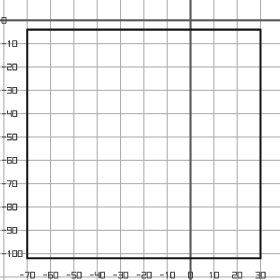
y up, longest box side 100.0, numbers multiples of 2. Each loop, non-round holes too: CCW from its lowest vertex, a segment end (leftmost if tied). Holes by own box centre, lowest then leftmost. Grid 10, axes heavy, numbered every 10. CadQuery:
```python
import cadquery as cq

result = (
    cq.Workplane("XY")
    .moveTo(-70.0, -102.0)
    .lineTo(30.0, -102.0)
    .lineTo(30.0, -4.0)
    .lineTo(-70.0, -4.0)
    .close()
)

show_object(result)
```